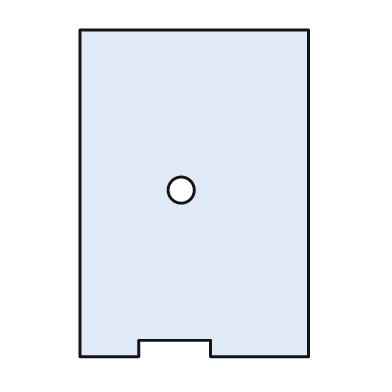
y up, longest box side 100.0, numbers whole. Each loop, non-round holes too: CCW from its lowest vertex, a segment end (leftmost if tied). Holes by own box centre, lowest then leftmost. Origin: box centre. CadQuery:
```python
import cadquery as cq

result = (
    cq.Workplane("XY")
    .moveTo(-35.0, -50.0)
    .lineTo(-17.0, -50.0)
    .lineTo(-17.0, -45.0)
    .lineTo(5.0, -45.0)
    .lineTo(5.0, -50.0)
    .lineTo(35.0, -50.0)
    .lineTo(35.0, 50.0)
    .lineTo(-35.0, 50.0)
    .close()
    .moveTo(-4.0, 1.0)
    .circle(4.0)
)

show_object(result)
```